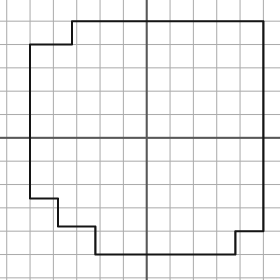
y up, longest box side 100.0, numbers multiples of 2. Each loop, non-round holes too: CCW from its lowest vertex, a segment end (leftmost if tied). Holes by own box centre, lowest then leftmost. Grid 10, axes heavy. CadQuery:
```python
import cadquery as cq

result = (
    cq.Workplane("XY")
    .moveTo(-22.0, -50.0)
    .lineTo(38.0, -50.0)
    .lineTo(38.0, -40.0)
    .lineTo(50.0, -40.0)
    .lineTo(50.0, 50.0)
    .lineTo(-32.0, 50.0)
    .lineTo(-32.0, 40.0)
    .lineTo(-50.0, 40.0)
    .lineTo(-50.0, -26.0)
    .lineTo(-38.0, -26.0)
    .lineTo(-38.0, -38.0)
    .lineTo(-22.0, -38.0)
    .close()
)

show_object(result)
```